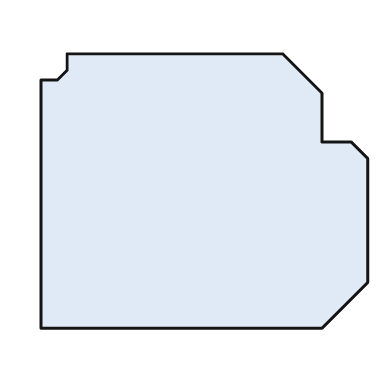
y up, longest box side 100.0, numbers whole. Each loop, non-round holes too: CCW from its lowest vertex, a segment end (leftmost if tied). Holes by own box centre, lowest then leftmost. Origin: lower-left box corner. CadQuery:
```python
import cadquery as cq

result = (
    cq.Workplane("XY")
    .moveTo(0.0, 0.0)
    .lineTo(86.0, 0.0)
    .lineTo(100.0, 14.0)
    .lineTo(100.0, 52.0)
    .lineTo(95.0, 57.0)
    .lineTo(86.0, 57.0)
    .lineTo(86.0, 72.0)
    .lineTo(74.0, 84.0)
    .lineTo(8.0, 84.0)
    .lineTo(8.0, 79.0)
    .lineTo(5.0, 76.0)
    .lineTo(0.0, 76.0)
    .close()
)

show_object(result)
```